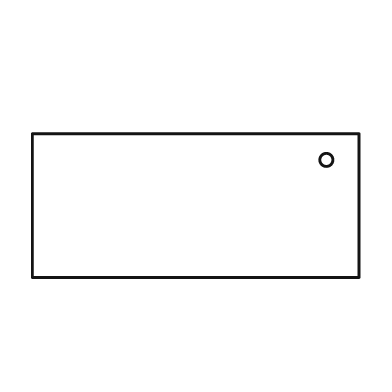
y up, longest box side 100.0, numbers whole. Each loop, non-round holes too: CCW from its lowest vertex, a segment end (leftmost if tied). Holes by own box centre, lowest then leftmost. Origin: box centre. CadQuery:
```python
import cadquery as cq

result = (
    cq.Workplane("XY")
    .moveTo(-50.0, -22.0)
    .lineTo(50.0, -22.0)
    .lineTo(50.0, 22.0)
    .lineTo(-50.0, 22.0)
    .close()
    .moveTo(40.0, 14.0)
    .circle(2.0)
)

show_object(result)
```